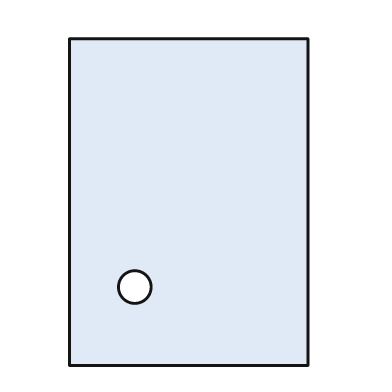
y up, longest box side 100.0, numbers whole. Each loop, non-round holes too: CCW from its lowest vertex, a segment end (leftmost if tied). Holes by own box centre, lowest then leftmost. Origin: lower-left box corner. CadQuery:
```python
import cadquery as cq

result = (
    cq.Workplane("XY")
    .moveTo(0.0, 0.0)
    .lineTo(73.0, 0.0)
    .lineTo(73.0, 100.0)
    .lineTo(0.0, 100.0)
    .close()
    .moveTo(20.0, 24.0)
    .circle(5.0)
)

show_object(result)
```